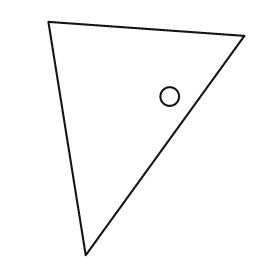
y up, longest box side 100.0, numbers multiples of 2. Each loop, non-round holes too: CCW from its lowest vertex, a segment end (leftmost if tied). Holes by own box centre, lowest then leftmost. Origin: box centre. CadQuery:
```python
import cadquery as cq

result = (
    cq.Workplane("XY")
    .moveTo(-26.0, -50.0)
    .lineTo(42.0, 44.0)
    .lineTo(-42.0, 50.0)
    .close()
    .moveTo(10.0, 18.0)
    .circle(4.0)
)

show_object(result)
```